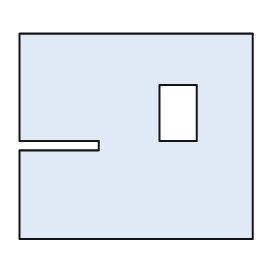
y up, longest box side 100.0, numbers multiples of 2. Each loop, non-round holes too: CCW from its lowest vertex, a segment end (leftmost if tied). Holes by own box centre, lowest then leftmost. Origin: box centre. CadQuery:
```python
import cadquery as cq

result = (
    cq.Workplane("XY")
    .moveTo(-50.0, -44.0)
    .lineTo(50.0, -44.0)
    .lineTo(50.0, 44.0)
    .lineTo(-50.0, 44.0)
    .lineTo(-50.0, -2.0)
    .lineTo(-16.0, -2.0)
    .lineTo(-16.0, -6.0)
    .lineTo(-50.0, -6.0)
    .close()
    .moveTo(10.0, -2.0)
    .lineTo(26.0, -2.0)
    .lineTo(26.0, 22.0)
    .lineTo(10.0, 22.0)
    .close()
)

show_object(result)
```